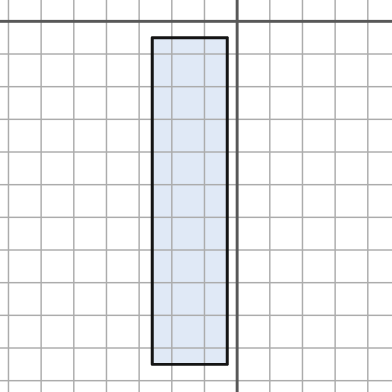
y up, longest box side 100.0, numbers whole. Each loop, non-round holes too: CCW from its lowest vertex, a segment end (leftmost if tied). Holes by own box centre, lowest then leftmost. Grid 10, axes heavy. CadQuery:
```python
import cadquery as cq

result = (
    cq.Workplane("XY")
    .moveTo(-26.0, -105.0)
    .lineTo(-3.0, -105.0)
    .lineTo(-3.0, -5.0)
    .lineTo(-26.0, -5.0)
    .close()
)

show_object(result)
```